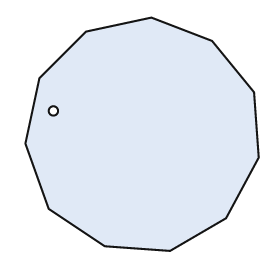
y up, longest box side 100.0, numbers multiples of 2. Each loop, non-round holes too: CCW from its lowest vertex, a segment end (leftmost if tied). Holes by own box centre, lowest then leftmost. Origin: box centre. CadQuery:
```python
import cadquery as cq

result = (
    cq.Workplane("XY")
    .moveTo(12.0, -50.0)
    .lineTo(36.0, -36.0)
    .lineTo(50.0, -10.0)
    .lineTo(48.0, 18.0)
    .lineTo(30.0, 40.0)
    .lineTo(4.0, 50.0)
    .lineTo(-24.0, 44.0)
    .lineTo(-44.0, 24.0)
    .lineTo(-50.0, -4.0)
    .lineTo(-40.0, -32.0)
    .lineTo(-16.0, -48.0)
    .close()
    .moveTo(-38.0, 10.0)
    .circle(2.0)
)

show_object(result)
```